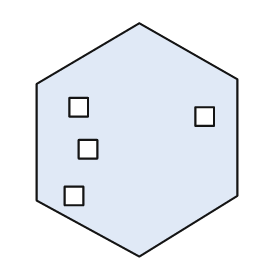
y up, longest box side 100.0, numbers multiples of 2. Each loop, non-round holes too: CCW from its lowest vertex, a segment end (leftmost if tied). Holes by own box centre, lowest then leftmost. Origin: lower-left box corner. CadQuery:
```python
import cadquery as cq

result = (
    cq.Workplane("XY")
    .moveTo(44.0, 0.0)
    .lineTo(86.0, 26.0)
    .lineTo(86.0, 76.0)
    .lineTo(44.0, 100.0)
    .lineTo(0.0, 74.0)
    .lineTo(0.0, 24.0)
    .close()
    .moveTo(12.0, 22.0)
    .lineTo(20.0, 22.0)
    .lineTo(20.0, 30.0)
    .lineTo(12.0, 30.0)
    .close()
    .moveTo(18.0, 42.0)
    .lineTo(26.0, 42.0)
    .lineTo(26.0, 50.0)
    .lineTo(18.0, 50.0)
    .close()
    .moveTo(68.0, 56.0)
    .lineTo(76.0, 56.0)
    .lineTo(76.0, 64.0)
    .lineTo(68.0, 64.0)
    .close()
    .moveTo(14.0, 60.0)
    .lineTo(22.0, 60.0)
    .lineTo(22.0, 68.0)
    .lineTo(14.0, 68.0)
    .close()
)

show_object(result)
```